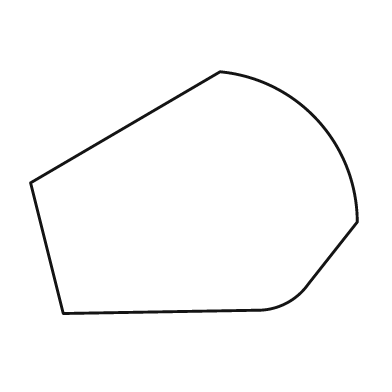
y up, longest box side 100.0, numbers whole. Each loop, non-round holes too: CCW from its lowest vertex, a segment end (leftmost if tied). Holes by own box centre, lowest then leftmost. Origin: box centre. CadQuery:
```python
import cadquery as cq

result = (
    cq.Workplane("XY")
    .moveTo(-40.0, -37.0)
    .lineTo(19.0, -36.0)
    .threePointArc((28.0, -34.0), (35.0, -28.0))
    .lineTo(50.0, -9.0)
    .threePointArc((38.0, 22.0), (8.0, 37.0))
    .lineTo(-50.0, 3.0)
    .close()
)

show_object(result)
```